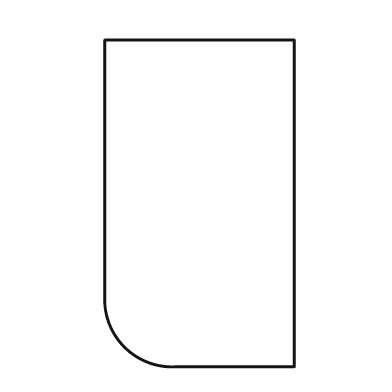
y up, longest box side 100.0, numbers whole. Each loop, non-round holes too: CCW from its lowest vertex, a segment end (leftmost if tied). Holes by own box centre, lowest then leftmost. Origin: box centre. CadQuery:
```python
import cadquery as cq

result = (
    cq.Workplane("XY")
    .moveTo(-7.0, -50.0)
    .lineTo(29.0, -50.0)
    .lineTo(29.0, 50.0)
    .lineTo(-29.0, 50.0)
    .lineTo(-29.0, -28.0)
    .threePointArc((-23.0, -44.0), (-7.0, -50.0))
    .close()
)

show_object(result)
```